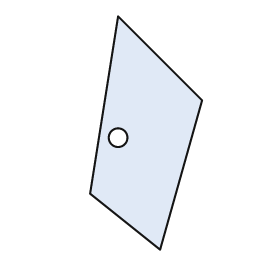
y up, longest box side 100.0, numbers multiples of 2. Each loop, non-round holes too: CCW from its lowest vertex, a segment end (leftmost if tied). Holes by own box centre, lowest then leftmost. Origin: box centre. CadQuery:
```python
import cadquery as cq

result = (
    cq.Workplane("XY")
    .moveTo(6.0, -50.0)
    .lineTo(24.0, 14.0)
    .lineTo(-12.0, 50.0)
    .lineTo(-24.0, -26.0)
    .close()
    .moveTo(-12.0, -2.0)
    .circle(4.0)
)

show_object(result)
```